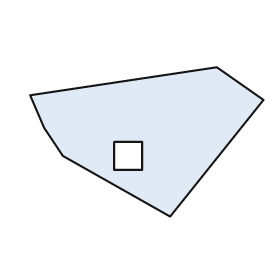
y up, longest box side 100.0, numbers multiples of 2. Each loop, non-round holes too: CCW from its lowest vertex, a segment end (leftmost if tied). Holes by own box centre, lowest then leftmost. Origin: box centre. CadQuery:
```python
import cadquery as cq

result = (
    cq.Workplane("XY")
    .moveTo(10.0, -32.0)
    .lineTo(50.0, 18.0)
    .lineTo(30.0, 32.0)
    .lineTo(-50.0, 20.0)
    .lineTo(-44.0, 6.0)
    .lineTo(-36.0, -6.0)
    .close()
    .moveTo(-14.0, -12.0)
    .lineTo(-2.0, -12.0)
    .lineTo(-2.0, 0.0)
    .lineTo(-14.0, 0.0)
    .close()
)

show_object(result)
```